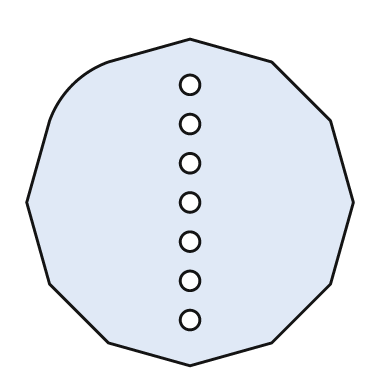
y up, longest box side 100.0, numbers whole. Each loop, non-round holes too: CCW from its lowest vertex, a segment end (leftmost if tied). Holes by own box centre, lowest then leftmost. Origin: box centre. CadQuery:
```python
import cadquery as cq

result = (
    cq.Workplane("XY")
    .moveTo(0.0, -50.0)
    .lineTo(25.0, -43.0)
    .lineTo(43.0, -25.0)
    .lineTo(50.0, 0.0)
    .lineTo(43.0, 25.0)
    .lineTo(25.0, 43.0)
    .lineTo(0.0, 50.0)
    .lineTo(-25.0, 43.0)
    .threePointArc((-36.0, 36.0), (-43.0, 25.0))
    .lineTo(-50.0, 0.0)
    .lineTo(-43.0, -25.0)
    .lineTo(-25.0, -43.0)
    .close()
    .moveTo(0.0, -36.0)
    .circle(3.0)
    .moveTo(0.0, -24.0)
    .circle(3.0)
    .moveTo(0.0, -12.0)
    .circle(3.0)
    .moveTo(0.0, 0.0)
    .circle(3.0)
    .moveTo(0.0, 12.0)
    .circle(3.0)
    .moveTo(0.0, 24.0)
    .circle(3.0)
    .moveTo(0.0, 36.0)
    .circle(3.0)
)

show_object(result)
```